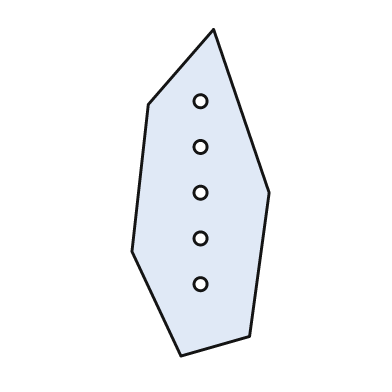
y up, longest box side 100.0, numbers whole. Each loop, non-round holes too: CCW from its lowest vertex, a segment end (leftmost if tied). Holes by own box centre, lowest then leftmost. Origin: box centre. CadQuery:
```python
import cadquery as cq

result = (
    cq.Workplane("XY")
    .moveTo(-6.0, -50.0)
    .lineTo(15.0, -44.0)
    .lineTo(21.0, 0.0)
    .lineTo(4.0, 50.0)
    .lineTo(-16.0, 27.0)
    .lineTo(-21.0, -18.0)
    .close()
    .moveTo(0.0, -28.0)
    .circle(2.0)
    .moveTo(0.0, -14.0)
    .circle(2.0)
    .moveTo(0.0, 0.0)
    .circle(2.0)
    .moveTo(0.0, 14.0)
    .circle(2.0)
    .moveTo(0.0, 28.0)
    .circle(2.0)
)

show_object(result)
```